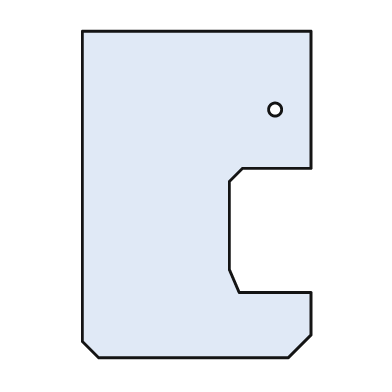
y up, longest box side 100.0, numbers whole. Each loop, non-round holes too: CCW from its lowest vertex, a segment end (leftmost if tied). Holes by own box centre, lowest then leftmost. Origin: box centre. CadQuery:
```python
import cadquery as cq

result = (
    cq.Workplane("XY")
    .moveTo(-30.0, -50.0)
    .lineTo(28.0, -50.0)
    .lineTo(35.0, -43.0)
    .lineTo(35.0, -30.0)
    .lineTo(13.0, -30.0)
    .lineTo(10.0, -23.0)
    .lineTo(10.0, 4.0)
    .lineTo(14.0, 8.0)
    .lineTo(35.0, 8.0)
    .lineTo(35.0, 50.0)
    .lineTo(-35.0, 50.0)
    .lineTo(-35.0, -45.0)
    .close()
    .moveTo(24.0, 26.0)
    .circle(2.0)
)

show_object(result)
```